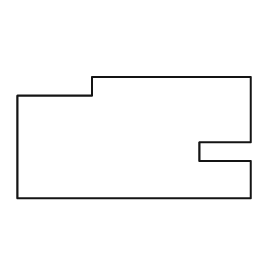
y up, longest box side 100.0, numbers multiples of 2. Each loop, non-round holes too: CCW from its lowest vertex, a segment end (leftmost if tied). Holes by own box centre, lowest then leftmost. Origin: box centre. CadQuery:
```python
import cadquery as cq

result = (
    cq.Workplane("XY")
    .moveTo(-50.0, -26.0)
    .lineTo(50.0, -26.0)
    .lineTo(50.0, -10.0)
    .lineTo(28.0, -10.0)
    .lineTo(28.0, -2.0)
    .lineTo(50.0, -2.0)
    .lineTo(50.0, 26.0)
    .lineTo(-18.0, 26.0)
    .lineTo(-18.0, 18.0)
    .lineTo(-50.0, 18.0)
    .close()
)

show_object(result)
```